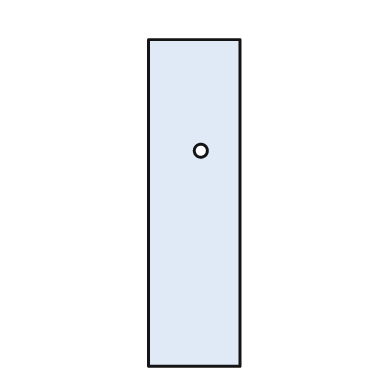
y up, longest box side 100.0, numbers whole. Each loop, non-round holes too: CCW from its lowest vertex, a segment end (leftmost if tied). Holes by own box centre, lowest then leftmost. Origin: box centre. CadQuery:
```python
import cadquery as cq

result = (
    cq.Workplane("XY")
    .moveTo(-14.0, -50.0)
    .lineTo(14.0, -50.0)
    .lineTo(14.0, 50.0)
    .lineTo(-14.0, 50.0)
    .close()
    .moveTo(2.0, 16.0)
    .circle(2.0)
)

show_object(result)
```